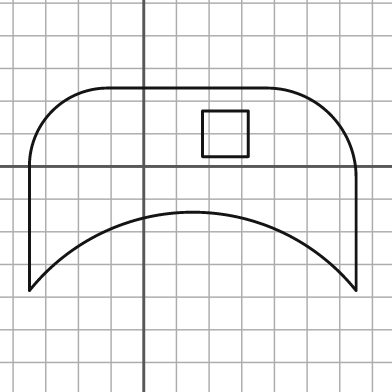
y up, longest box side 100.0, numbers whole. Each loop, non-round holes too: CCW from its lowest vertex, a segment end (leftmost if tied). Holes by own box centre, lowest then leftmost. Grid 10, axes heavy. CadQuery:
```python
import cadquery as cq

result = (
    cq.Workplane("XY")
    .moveTo(-35.0, -38.0)
    .threePointArc((15.0, -14.0), (65.0, -38.0))
    .lineTo(65.0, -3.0)
    .threePointArc((57.0, 16.0), (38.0, 24.0))
    .lineTo(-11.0, 24.0)
    .threePointArc((-28.0, 17.0), (-35.0, 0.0))
    .close()
    .moveTo(18.0, 3.0)
    .lineTo(32.0, 3.0)
    .lineTo(32.0, 17.0)
    .lineTo(18.0, 17.0)
    .close()
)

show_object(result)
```